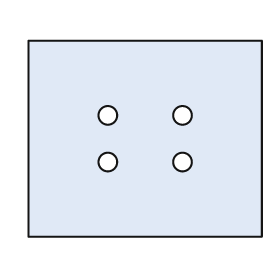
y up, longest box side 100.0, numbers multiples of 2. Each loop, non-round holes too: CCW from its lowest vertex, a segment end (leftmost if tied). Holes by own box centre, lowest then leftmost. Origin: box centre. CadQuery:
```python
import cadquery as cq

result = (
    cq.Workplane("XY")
    .moveTo(-50.0, -42.0)
    .lineTo(50.0, -42.0)
    .lineTo(50.0, 42.0)
    .lineTo(-50.0, 42.0)
    .close()
    .moveTo(-16.0, -10.0)
    .circle(4.0)
    .moveTo(16.0, -10.0)
    .circle(4.0)
    .moveTo(-16.0, 10.0)
    .circle(4.0)
    .moveTo(16.0, 10.0)
    .circle(4.0)
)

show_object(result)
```